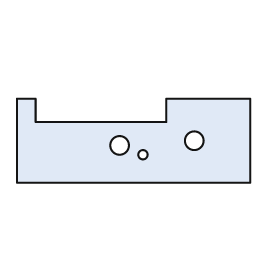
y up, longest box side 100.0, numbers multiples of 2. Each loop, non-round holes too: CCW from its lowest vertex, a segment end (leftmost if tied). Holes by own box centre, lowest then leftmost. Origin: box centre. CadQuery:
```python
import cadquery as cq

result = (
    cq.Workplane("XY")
    .moveTo(-50.0, -18.0)
    .lineTo(50.0, -18.0)
    .lineTo(50.0, 18.0)
    .lineTo(14.0, 18.0)
    .lineTo(14.0, 8.0)
    .lineTo(-42.0, 8.0)
    .lineTo(-42.0, 18.0)
    .lineTo(-50.0, 18.0)
    .close()
    .moveTo(4.0, -6.0)
    .circle(2.0)
    .moveTo(-6.0, -2.0)
    .circle(4.0)
    .moveTo(26.0, 0.0)
    .circle(4.0)
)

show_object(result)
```